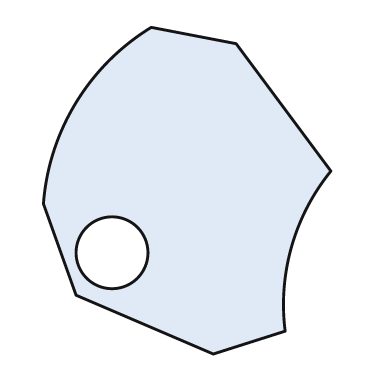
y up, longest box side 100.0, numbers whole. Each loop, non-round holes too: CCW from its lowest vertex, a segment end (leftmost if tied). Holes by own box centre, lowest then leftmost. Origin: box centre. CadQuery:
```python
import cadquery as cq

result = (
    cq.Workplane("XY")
    .moveTo(8.0, -50.0)
    .lineTo(30.0, -43.0)
    .threePointArc((32.0, -17.0), (44.0, 6.0))
    .lineTo(15.0, 45.0)
    .lineTo(-11.0, 50.0)
    .threePointArc((-34.0, 27.0), (-44.0, -4.0))
    .lineTo(-34.0, -32.0)
    .close()
    .moveTo(-23.0, -19.0)
    .circle(11.0)
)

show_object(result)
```